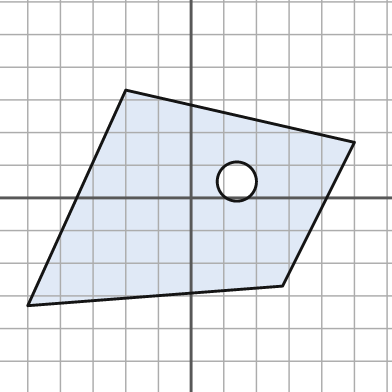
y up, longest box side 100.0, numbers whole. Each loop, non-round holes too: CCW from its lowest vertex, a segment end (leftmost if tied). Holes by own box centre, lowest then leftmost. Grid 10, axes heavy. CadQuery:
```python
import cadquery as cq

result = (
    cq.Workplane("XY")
    .moveTo(-50.0, -33.0)
    .lineTo(28.0, -27.0)
    .lineTo(50.0, 17.0)
    .lineTo(-20.0, 33.0)
    .close()
    .moveTo(14.0, 5.0)
    .circle(6.0)
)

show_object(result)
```